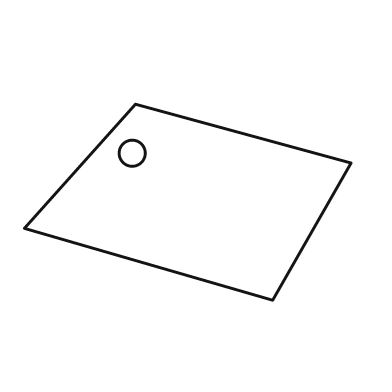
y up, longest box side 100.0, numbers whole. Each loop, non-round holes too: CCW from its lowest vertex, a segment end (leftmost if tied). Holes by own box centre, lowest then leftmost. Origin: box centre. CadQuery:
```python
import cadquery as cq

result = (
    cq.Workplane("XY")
    .moveTo(26.0, -30.0)
    .lineTo(50.0, 12.0)
    .lineTo(-16.0, 30.0)
    .lineTo(-50.0, -8.0)
    .close()
    .moveTo(-17.0, 15.0)
    .circle(4.0)
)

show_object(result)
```